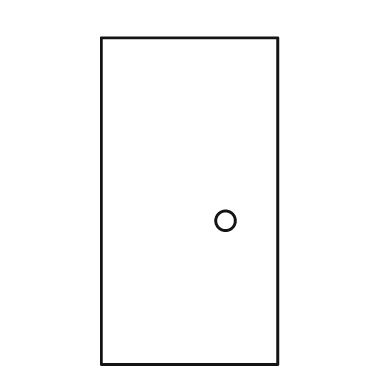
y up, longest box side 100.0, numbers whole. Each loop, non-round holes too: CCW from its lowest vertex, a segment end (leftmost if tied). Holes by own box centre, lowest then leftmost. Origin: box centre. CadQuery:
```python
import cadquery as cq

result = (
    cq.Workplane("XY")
    .moveTo(-27.0, -50.0)
    .lineTo(27.0, -50.0)
    .lineTo(27.0, 50.0)
    .lineTo(-27.0, 50.0)
    .close()
    .moveTo(11.0, -6.0)
    .circle(3.0)
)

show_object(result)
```